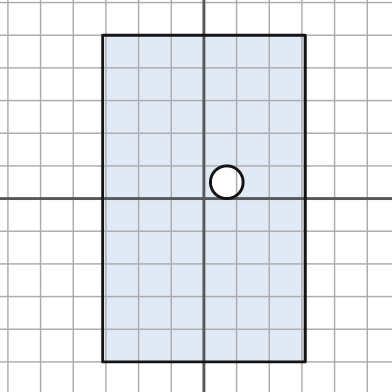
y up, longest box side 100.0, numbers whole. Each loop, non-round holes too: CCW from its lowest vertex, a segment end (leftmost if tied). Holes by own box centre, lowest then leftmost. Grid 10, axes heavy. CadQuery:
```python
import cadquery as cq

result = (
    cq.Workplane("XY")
    .moveTo(-31.0, -50.0)
    .lineTo(31.0, -50.0)
    .lineTo(31.0, 50.0)
    .lineTo(-31.0, 50.0)
    .close()
    .moveTo(7.0, 5.0)
    .circle(5.0)
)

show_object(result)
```